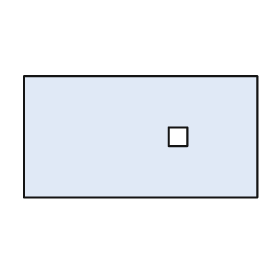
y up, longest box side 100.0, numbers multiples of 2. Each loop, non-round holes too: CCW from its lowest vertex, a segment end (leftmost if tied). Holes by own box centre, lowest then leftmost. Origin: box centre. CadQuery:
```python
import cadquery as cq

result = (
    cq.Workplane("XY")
    .moveTo(-50.0, -26.0)
    .lineTo(50.0, -26.0)
    .lineTo(50.0, 26.0)
    .lineTo(-50.0, 26.0)
    .close()
    .moveTo(12.0, -4.0)
    .lineTo(20.0, -4.0)
    .lineTo(20.0, 4.0)
    .lineTo(12.0, 4.0)
    .close()
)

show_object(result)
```